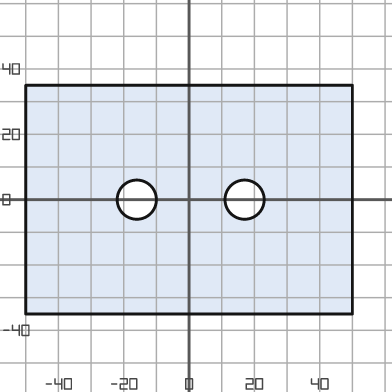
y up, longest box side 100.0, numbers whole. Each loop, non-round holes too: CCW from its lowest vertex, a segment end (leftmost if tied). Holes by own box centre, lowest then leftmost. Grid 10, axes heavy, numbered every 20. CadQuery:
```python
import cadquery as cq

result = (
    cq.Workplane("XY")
    .moveTo(-50.0, -35.0)
    .lineTo(50.0, -35.0)
    .lineTo(50.0, 35.0)
    .lineTo(-50.0, 35.0)
    .close()
    .moveTo(-16.0, 0.0)
    .circle(6.0)
    .moveTo(17.0, 0.0)
    .circle(6.0)
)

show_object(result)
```